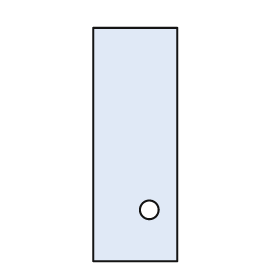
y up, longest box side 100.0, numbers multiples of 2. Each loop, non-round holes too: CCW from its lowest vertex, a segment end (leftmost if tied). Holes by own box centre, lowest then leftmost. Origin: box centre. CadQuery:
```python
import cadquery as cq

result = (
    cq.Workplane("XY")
    .moveTo(-18.0, -50.0)
    .lineTo(18.0, -50.0)
    .lineTo(18.0, 50.0)
    .lineTo(-18.0, 50.0)
    .close()
    .moveTo(6.0, -28.0)
    .circle(4.0)
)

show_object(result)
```